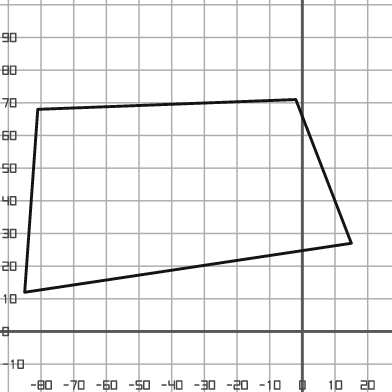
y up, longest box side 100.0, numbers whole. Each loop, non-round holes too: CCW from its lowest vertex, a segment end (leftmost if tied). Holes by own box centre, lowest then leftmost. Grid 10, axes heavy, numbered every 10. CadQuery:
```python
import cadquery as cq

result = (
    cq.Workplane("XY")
    .moveTo(-85.0, 12.0)
    .lineTo(15.0, 27.0)
    .lineTo(-2.0, 71.0)
    .lineTo(-81.0, 68.0)
    .close()
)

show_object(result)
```